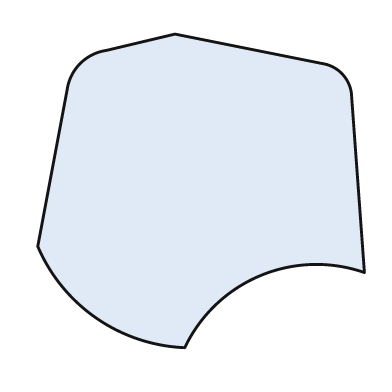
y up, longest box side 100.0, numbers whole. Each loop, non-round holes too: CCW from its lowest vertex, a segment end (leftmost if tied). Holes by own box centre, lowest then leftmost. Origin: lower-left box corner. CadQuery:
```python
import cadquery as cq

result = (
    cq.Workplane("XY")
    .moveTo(45.0, 0.0)
    .threePointArc((68.0, 22.0), (100.0, 23.0))
    .lineTo(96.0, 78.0)
    .threePointArc((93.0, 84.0), (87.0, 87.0))
    .lineTo(42.0, 96.0)
    .lineTo(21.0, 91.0)
    .threePointArc((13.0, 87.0), (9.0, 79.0))
    .lineTo(0.0, 31.0)
    .threePointArc((18.0, 9.0), (45.0, 0.0))
    .close()
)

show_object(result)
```